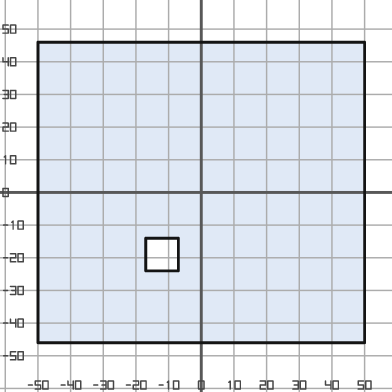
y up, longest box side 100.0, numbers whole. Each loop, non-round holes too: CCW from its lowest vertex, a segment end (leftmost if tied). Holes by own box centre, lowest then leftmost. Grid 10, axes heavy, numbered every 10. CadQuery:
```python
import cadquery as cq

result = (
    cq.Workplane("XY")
    .moveTo(-50.0, -46.0)
    .lineTo(50.0, -46.0)
    .lineTo(50.0, 46.0)
    .lineTo(-50.0, 46.0)
    .close()
    .moveTo(-17.0, -24.0)
    .lineTo(-7.0, -24.0)
    .lineTo(-7.0, -14.0)
    .lineTo(-17.0, -14.0)
    .close()
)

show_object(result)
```